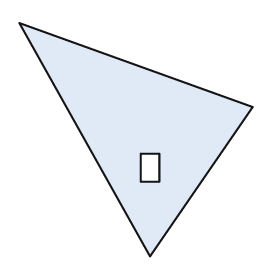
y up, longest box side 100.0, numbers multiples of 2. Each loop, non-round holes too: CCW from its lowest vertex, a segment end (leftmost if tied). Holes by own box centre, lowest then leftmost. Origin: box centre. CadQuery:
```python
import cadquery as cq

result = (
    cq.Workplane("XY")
    .moveTo(6.0, -50.0)
    .lineTo(50.0, 14.0)
    .lineTo(-50.0, 50.0)
    .close()
    .moveTo(2.0, -18.0)
    .lineTo(10.0, -18.0)
    .lineTo(10.0, -6.0)
    .lineTo(2.0, -6.0)
    .close()
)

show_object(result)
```